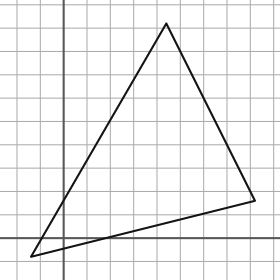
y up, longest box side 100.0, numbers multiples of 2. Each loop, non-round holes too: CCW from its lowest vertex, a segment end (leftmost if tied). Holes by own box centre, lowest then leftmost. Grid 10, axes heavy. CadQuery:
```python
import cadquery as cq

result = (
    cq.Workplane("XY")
    .moveTo(-14.0, -8.0)
    .lineTo(82.0, 16.0)
    .lineTo(44.0, 92.0)
    .close()
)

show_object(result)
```